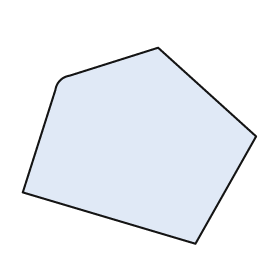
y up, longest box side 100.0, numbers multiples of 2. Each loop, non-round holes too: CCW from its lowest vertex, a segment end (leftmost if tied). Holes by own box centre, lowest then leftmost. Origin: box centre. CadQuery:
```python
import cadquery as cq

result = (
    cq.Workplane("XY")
    .moveTo(24.0, -42.0)
    .lineTo(50.0, 4.0)
    .lineTo(8.0, 42.0)
    .lineTo(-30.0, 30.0)
    .threePointArc((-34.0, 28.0), (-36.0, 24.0))
    .lineTo(-50.0, -20.0)
    .close()
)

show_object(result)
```